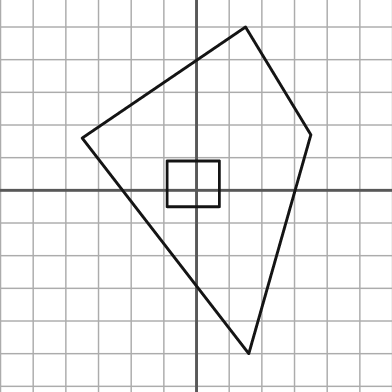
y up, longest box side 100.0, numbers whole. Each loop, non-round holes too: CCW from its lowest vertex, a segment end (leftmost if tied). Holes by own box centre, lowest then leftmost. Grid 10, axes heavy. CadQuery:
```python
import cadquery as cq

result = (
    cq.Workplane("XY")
    .moveTo(16.0, -50.0)
    .lineTo(35.0, 17.0)
    .lineTo(15.0, 50.0)
    .lineTo(-35.0, 16.0)
    .close()
    .moveTo(-9.0, -5.0)
    .lineTo(7.0, -5.0)
    .lineTo(7.0, 9.0)
    .lineTo(-9.0, 9.0)
    .close()
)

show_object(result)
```